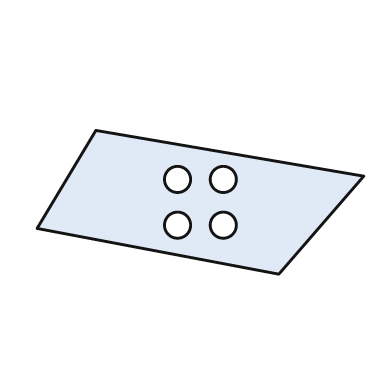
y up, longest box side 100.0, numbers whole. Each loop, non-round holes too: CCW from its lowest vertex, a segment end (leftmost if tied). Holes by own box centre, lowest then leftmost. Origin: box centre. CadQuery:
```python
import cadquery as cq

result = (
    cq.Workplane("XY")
    .moveTo(24.0, -22.0)
    .lineTo(50.0, 8.0)
    .lineTo(-32.0, 22.0)
    .lineTo(-50.0, -8.0)
    .close()
    .moveTo(-7.0, -7.0)
    .circle(4.0)
    .moveTo(7.0, -7.0)
    .circle(4.0)
    .moveTo(-7.0, 7.0)
    .circle(4.0)
    .moveTo(7.0, 7.0)
    .circle(4.0)
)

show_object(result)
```